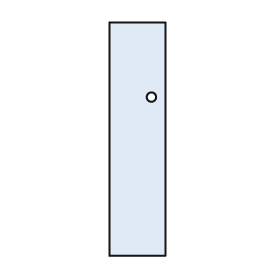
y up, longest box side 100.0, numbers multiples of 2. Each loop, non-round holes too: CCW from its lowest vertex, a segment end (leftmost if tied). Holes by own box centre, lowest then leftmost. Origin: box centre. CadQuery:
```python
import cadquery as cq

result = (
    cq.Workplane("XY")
    .moveTo(-12.0, -50.0)
    .lineTo(12.0, -50.0)
    .lineTo(12.0, 50.0)
    .lineTo(-12.0, 50.0)
    .close()
    .moveTo(6.0, 18.0)
    .circle(2.0)
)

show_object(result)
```